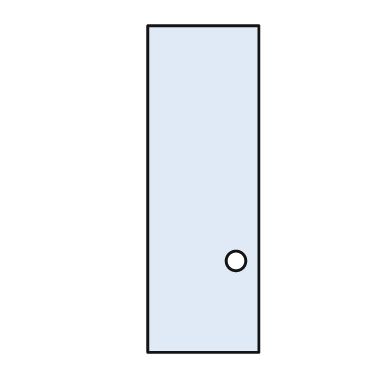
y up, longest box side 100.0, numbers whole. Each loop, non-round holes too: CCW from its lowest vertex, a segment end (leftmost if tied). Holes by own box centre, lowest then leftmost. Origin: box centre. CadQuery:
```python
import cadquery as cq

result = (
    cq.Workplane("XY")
    .moveTo(-17.0, -50.0)
    .lineTo(17.0, -50.0)
    .lineTo(17.0, 50.0)
    .lineTo(-17.0, 50.0)
    .close()
    .moveTo(10.0, -22.0)
    .circle(3.0)
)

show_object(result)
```